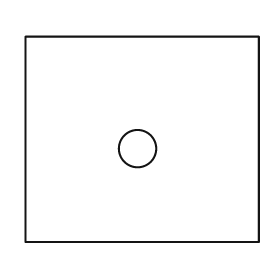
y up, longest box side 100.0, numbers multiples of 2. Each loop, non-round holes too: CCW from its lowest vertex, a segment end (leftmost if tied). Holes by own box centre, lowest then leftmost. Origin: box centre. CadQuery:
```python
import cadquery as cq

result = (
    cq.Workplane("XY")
    .moveTo(-50.0, -44.0)
    .lineTo(50.0, -44.0)
    .lineTo(50.0, 44.0)
    .lineTo(-50.0, 44.0)
    .close()
    .moveTo(-2.0, -4.0)
    .circle(8.0)
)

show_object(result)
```